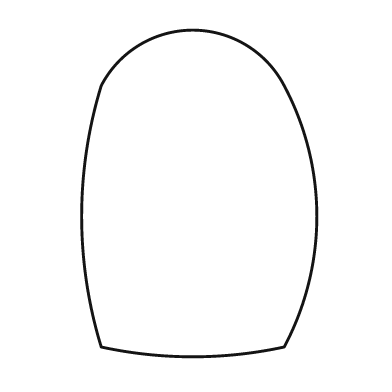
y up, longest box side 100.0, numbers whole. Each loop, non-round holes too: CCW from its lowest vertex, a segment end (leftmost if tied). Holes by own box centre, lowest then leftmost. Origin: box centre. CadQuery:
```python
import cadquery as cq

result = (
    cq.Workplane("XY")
    .moveTo(-30.0, -47.0)
    .threePointArc((-2.0, -50.0), (26.0, -47.0))
    .threePointArc((36.0, -7.0), (26.0, 33.0))
    .threePointArc((-2.0, 50.0), (-30.0, 33.0))
    .threePointArc((-36.0, -7.0), (-30.0, -47.0))
    .close()
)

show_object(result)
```